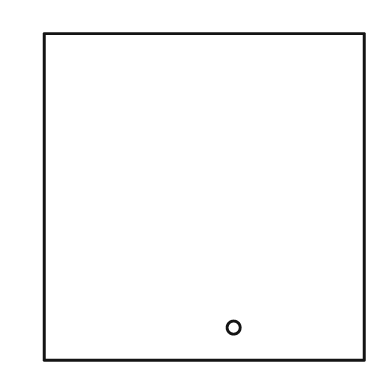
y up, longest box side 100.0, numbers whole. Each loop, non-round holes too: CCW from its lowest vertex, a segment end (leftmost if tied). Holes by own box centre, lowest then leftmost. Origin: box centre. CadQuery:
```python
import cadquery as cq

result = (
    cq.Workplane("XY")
    .moveTo(-49.0, -50.0)
    .lineTo(49.0, -50.0)
    .lineTo(49.0, 50.0)
    .lineTo(-49.0, 50.0)
    .close()
    .moveTo(9.0, -40.0)
    .circle(2.0)
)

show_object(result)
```